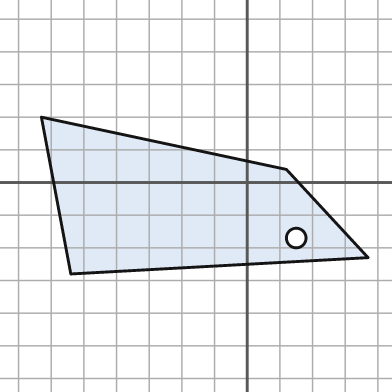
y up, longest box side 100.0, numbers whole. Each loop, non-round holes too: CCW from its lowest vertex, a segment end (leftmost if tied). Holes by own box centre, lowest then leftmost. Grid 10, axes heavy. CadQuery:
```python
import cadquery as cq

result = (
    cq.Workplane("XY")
    .moveTo(-54.0, -28.0)
    .lineTo(37.0, -23.0)
    .lineTo(12.0, 4.0)
    .lineTo(-63.0, 20.0)
    .close()
    .moveTo(15.0, -17.0)
    .circle(3.0)
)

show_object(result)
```